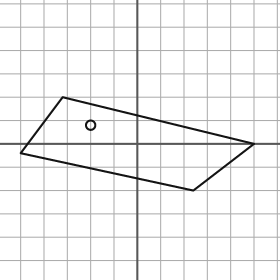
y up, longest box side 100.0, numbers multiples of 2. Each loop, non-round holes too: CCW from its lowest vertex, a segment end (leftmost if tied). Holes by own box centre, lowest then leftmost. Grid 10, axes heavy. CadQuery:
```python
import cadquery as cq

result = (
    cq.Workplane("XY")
    .moveTo(24.0, -20.0)
    .lineTo(50.0, 0.0)
    .lineTo(-32.0, 20.0)
    .lineTo(-50.0, -4.0)
    .close()
    .moveTo(-20.0, 8.0)
    .circle(2.0)
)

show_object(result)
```